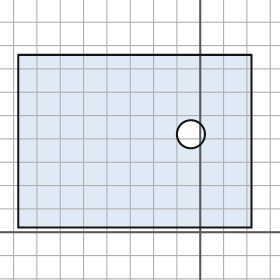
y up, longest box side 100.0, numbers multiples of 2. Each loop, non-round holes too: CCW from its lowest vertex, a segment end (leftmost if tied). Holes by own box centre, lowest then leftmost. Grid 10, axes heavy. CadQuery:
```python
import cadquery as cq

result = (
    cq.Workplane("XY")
    .moveTo(-78.0, 2.0)
    .lineTo(22.0, 2.0)
    .lineTo(22.0, 76.0)
    .lineTo(-78.0, 76.0)
    .close()
    .moveTo(-4.0, 42.0)
    .circle(6.0)
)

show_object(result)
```